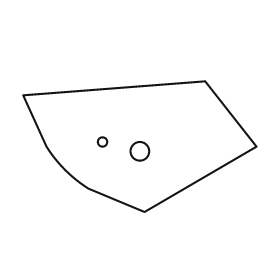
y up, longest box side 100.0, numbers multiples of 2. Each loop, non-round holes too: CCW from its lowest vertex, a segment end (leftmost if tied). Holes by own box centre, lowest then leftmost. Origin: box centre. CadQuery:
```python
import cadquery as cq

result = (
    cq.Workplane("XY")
    .moveTo(2.0, -28.0)
    .lineTo(50.0, 0.0)
    .lineTo(28.0, 28.0)
    .lineTo(-50.0, 22.0)
    .lineTo(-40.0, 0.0)
    .threePointArc((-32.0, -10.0), (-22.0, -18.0))
    .close()
    .moveTo(0.0, -2.0)
    .circle(4.0)
    .moveTo(-16.0, 2.0)
    .circle(2.0)
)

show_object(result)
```